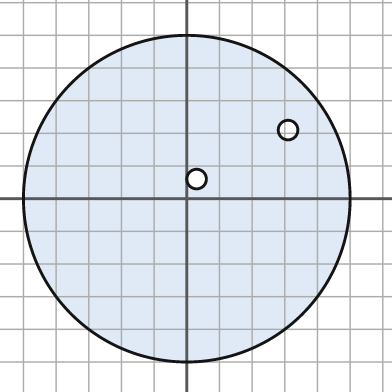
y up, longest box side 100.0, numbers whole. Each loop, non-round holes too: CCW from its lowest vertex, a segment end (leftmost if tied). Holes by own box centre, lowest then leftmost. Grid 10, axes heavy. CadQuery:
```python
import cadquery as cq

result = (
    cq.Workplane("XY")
    .moveTo(0.0, 0.0)
    .circle(50.0)
    .moveTo(3.0, 6.0)
    .circle(3.0)
    .moveTo(31.0, 21.0)
    .circle(3.0)
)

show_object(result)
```